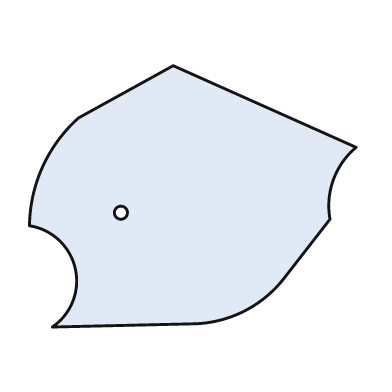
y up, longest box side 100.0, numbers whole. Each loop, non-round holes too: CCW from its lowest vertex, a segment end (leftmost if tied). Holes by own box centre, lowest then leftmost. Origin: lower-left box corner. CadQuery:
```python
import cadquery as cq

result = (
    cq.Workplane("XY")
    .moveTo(7.0, 0.0)
    .lineTo(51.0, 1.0)
    .threePointArc((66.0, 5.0), (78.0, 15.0))
    .lineTo(92.0, 33.0)
    .threePointArc((93.0, 45.0), (100.0, 55.0))
    .lineTo(44.0, 80.0)
    .lineTo(15.0, 64.0)
    .threePointArc((4.0, 49.0), (0.0, 31.0))
    .threePointArc((14.0, 18.0), (7.0, 0.0))
    .close()
    .moveTo(28.0, 35.0)
    .circle(2.0)
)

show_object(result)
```